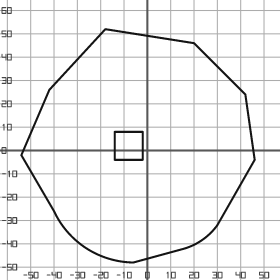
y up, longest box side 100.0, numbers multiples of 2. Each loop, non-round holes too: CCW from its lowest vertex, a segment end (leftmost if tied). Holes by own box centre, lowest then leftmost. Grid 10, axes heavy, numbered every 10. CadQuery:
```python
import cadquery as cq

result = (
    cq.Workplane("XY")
    .moveTo(-6.0, -48.0)
    .lineTo(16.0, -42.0)
    .threePointArc((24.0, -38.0), (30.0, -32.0))
    .lineTo(46.0, -4.0)
    .lineTo(42.0, 24.0)
    .lineTo(20.0, 46.0)
    .lineTo(-18.0, 52.0)
    .lineTo(-42.0, 26.0)
    .lineTo(-54.0, -2.0)
    .lineTo(-40.0, -26.0)
    .threePointArc((-26.0, -42.0), (-6.0, -48.0))
    .close()
    .moveTo(-14.0, -4.0)
    .lineTo(-2.0, -4.0)
    .lineTo(-2.0, 8.0)
    .lineTo(-14.0, 8.0)
    .close()
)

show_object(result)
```